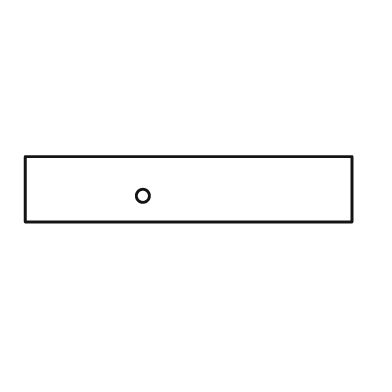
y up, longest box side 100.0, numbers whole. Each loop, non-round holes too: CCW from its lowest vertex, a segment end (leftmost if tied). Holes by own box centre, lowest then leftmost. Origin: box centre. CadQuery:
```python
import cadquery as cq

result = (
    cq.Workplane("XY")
    .moveTo(-50.0, -10.0)
    .lineTo(50.0, -10.0)
    .lineTo(50.0, 10.0)
    .lineTo(-50.0, 10.0)
    .close()
    .moveTo(-14.0, -2.0)
    .circle(2.0)
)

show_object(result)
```